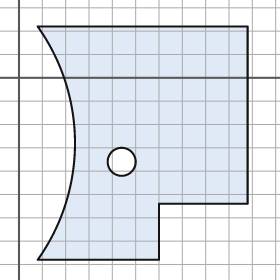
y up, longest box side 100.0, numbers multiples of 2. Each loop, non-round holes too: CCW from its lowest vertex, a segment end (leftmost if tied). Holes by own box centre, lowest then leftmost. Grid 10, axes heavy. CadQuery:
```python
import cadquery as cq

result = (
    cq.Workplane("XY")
    .moveTo(8.0, -78.0)
    .lineTo(60.0, -78.0)
    .lineTo(60.0, -54.0)
    .lineTo(98.0, -54.0)
    .lineTo(98.0, 22.0)
    .lineTo(8.0, 22.0)
    .threePointArc((24.0, -28.0), (8.0, -78.0))
    .close()
    .moveTo(44.0, -36.0)
    .circle(6.0)
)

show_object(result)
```